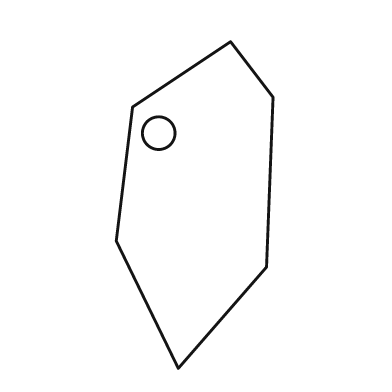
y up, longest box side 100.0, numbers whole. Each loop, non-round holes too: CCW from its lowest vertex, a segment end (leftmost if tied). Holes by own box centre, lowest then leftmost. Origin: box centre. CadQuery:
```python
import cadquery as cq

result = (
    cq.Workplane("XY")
    .moveTo(-5.0, -50.0)
    .lineTo(22.0, -19.0)
    .lineTo(24.0, 33.0)
    .lineTo(11.0, 50.0)
    .lineTo(-19.0, 30.0)
    .lineTo(-24.0, -11.0)
    .close()
    .moveTo(-11.0, 22.0)
    .circle(5.0)
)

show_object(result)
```